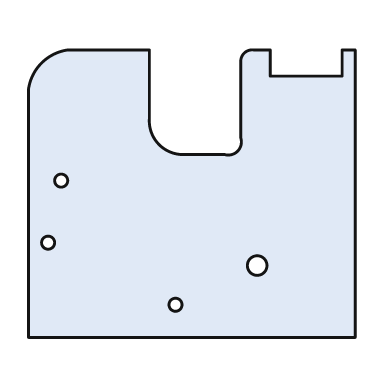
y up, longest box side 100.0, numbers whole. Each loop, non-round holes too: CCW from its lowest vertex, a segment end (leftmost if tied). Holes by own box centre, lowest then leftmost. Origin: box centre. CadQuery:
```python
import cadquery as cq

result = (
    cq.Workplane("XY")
    .moveTo(-50.0, -44.0)
    .lineTo(50.0, -44.0)
    .lineTo(50.0, 44.0)
    .lineTo(46.0, 44.0)
    .lineTo(46.0, 36.0)
    .lineTo(24.0, 36.0)
    .lineTo(24.0, 44.0)
    .lineTo(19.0, 44.0)
    .threePointArc((16.0, 43.0), (15.0, 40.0))
    .lineTo(15.0, 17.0)
    .threePointArc((14.0, 13.0), (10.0, 12.0))
    .lineTo(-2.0, 12.0)
    .threePointArc((-10.0, 15.0), (-13.0, 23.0))
    .lineTo(-13.0, 44.0)
    .lineTo(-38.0, 44.0)
    .threePointArc((-46.0, 40.0), (-50.0, 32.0))
    .close()
    .moveTo(-5.0, -34.0)
    .circle(2.0)
    .moveTo(20.0, -22.0)
    .circle(3.0)
    .moveTo(-44.0, -15.0)
    .circle(2.0)
    .moveTo(-40.0, 4.0)
    .circle(2.0)
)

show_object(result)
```